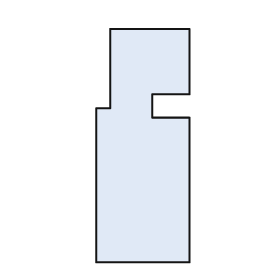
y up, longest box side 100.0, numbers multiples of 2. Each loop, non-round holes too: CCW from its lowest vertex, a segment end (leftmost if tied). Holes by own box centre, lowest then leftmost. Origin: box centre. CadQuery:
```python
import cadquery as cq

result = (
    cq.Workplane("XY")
    .moveTo(-20.0, -50.0)
    .lineTo(20.0, -50.0)
    .lineTo(20.0, 12.0)
    .lineTo(4.0, 12.0)
    .lineTo(4.0, 22.0)
    .lineTo(20.0, 22.0)
    .lineTo(20.0, 50.0)
    .lineTo(-14.0, 50.0)
    .lineTo(-14.0, 16.0)
    .lineTo(-20.0, 16.0)
    .close()
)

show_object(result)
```